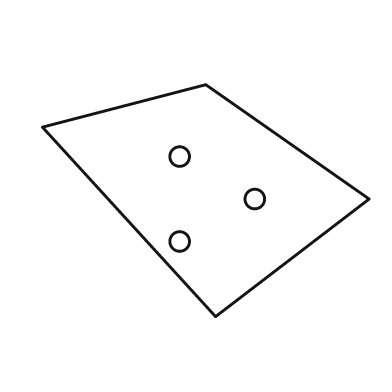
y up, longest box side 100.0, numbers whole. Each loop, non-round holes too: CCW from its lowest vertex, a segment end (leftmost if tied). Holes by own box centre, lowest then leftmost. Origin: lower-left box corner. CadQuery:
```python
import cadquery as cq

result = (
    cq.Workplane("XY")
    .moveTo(53.0, 0.0)
    .lineTo(100.0, 36.0)
    .lineTo(50.0, 71.0)
    .lineTo(0.0, 58.0)
    .close()
    .moveTo(42.0, 23.0)
    .circle(3.0)
    .moveTo(65.0, 36.0)
    .circle(3.0)
    .moveTo(42.0, 49.0)
    .circle(3.0)
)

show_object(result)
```